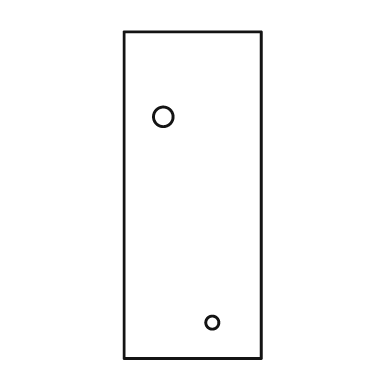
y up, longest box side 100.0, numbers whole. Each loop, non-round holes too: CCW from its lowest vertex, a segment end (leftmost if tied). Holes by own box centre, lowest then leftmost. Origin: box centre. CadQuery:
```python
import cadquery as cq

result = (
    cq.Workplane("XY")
    .moveTo(-21.0, -50.0)
    .lineTo(21.0, -50.0)
    .lineTo(21.0, 50.0)
    .lineTo(-21.0, 50.0)
    .close()
    .moveTo(6.0, -39.0)
    .circle(2.0)
    .moveTo(-9.0, 24.0)
    .circle(3.0)
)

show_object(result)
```